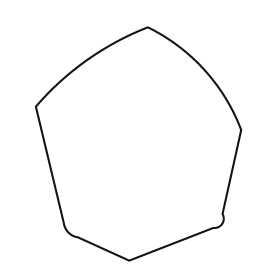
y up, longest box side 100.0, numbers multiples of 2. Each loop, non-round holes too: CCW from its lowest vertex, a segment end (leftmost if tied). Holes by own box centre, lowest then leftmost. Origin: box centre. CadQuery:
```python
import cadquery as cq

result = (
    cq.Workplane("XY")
    .moveTo(-4.0, -50.0)
    .lineTo(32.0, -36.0)
    .threePointArc((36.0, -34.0), (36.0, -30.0))
    .lineTo(44.0, 6.0)
    .threePointArc((28.0, 32.0), (4.0, 50.0))
    .threePointArc((-22.0, 36.0), (-44.0, 16.0))
    .lineTo(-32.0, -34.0)
    .threePointArc((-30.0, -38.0), (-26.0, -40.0))
    .close()
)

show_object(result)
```